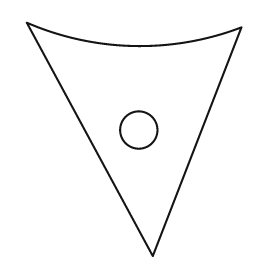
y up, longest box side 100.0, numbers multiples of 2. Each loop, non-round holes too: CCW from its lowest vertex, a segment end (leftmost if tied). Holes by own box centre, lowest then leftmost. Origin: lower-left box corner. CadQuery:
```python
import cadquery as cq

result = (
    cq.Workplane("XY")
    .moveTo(54.0, 0.0)
    .lineTo(92.0, 98.0)
    .threePointArc((46.0, 90.0), (0.0, 100.0))
    .close()
    .moveTo(48.0, 54.0)
    .circle(8.0)
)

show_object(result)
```